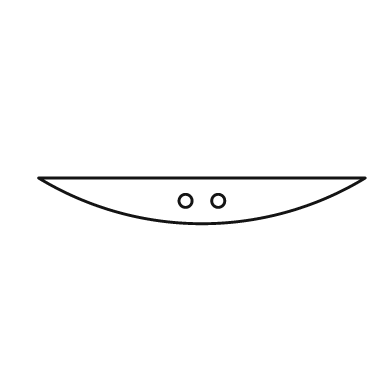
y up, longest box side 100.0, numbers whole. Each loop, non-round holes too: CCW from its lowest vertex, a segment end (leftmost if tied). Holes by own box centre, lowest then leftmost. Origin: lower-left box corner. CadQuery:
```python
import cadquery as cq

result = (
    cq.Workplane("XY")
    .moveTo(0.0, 14.0)
    .threePointArc((50.0, 0.0), (100.0, 14.0))
    .close()
    .moveTo(45.0, 7.0)
    .circle(2.0)
    .moveTo(55.0, 7.0)
    .circle(2.0)
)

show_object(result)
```